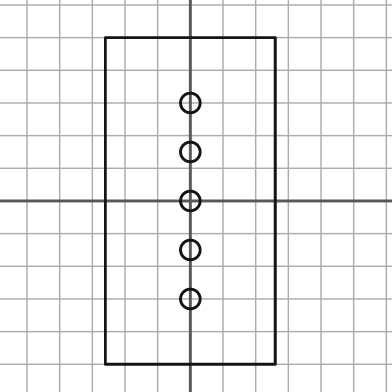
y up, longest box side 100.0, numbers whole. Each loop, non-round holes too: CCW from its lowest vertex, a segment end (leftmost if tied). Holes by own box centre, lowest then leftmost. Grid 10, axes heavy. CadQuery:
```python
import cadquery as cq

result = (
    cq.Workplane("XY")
    .moveTo(-26.0, -50.0)
    .lineTo(26.0, -50.0)
    .lineTo(26.0, 50.0)
    .lineTo(-26.0, 50.0)
    .close()
    .moveTo(0.0, -30.0)
    .circle(3.0)
    .moveTo(0.0, -15.0)
    .circle(3.0)
    .moveTo(0.0, 0.0)
    .circle(3.0)
    .moveTo(0.0, 15.0)
    .circle(3.0)
    .moveTo(0.0, 30.0)
    .circle(3.0)
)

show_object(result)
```